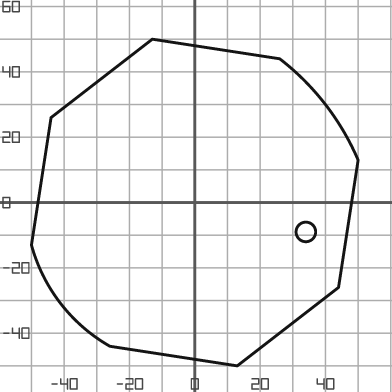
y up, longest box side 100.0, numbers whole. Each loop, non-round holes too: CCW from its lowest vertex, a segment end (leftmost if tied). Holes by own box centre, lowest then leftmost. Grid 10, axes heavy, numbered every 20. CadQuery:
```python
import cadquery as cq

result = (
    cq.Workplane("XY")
    .moveTo(13.0, -50.0)
    .lineTo(44.0, -26.0)
    .lineTo(50.0, 13.0)
    .threePointArc((40.0, 30.0), (26.0, 44.0))
    .lineTo(-13.0, 50.0)
    .lineTo(-44.0, 26.0)
    .lineTo(-50.0, -13.0)
    .threePointArc((-41.0, -31.0), (-26.0, -44.0))
    .close()
    .moveTo(34.0, -9.0)
    .circle(3.0)
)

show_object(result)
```